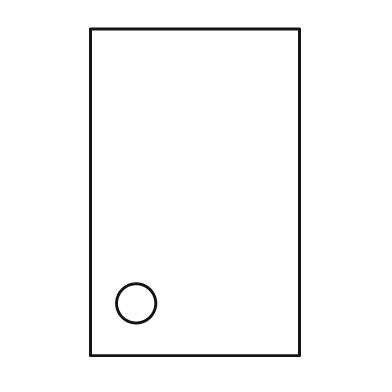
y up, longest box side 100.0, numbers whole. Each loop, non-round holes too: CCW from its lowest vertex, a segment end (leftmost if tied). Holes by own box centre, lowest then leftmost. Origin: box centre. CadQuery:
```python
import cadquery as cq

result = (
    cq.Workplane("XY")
    .moveTo(-32.0, -50.0)
    .lineTo(32.0, -50.0)
    .lineTo(32.0, 50.0)
    .lineTo(-32.0, 50.0)
    .close()
    .moveTo(-18.0, -34.0)
    .circle(6.0)
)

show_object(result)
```